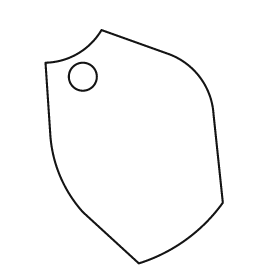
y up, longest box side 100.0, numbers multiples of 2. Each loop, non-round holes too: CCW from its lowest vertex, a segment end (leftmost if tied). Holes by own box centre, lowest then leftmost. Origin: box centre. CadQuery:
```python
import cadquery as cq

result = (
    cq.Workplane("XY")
    .moveTo(2.0, -50.0)
    .threePointArc((22.0, -40.0), (38.0, -24.0))
    .lineTo(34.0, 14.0)
    .threePointArc((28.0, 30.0), (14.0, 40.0))
    .lineTo(-14.0, 50.0)
    .threePointArc((-24.0, 40.0), (-38.0, 36.0))
    .lineTo(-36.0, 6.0)
    .threePointArc((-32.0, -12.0), (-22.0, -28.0))
    .close()
    .moveTo(-22.0, 30.0)
    .circle(6.0)
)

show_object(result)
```